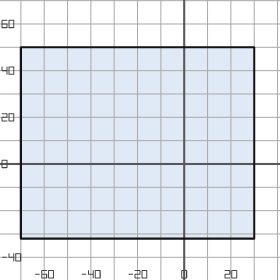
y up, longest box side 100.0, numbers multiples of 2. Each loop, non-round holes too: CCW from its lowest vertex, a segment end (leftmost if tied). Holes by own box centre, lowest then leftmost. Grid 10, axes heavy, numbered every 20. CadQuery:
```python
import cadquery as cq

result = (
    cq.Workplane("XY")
    .moveTo(-70.0, -32.0)
    .lineTo(30.0, -32.0)
    .lineTo(30.0, 50.0)
    .lineTo(-70.0, 50.0)
    .close()
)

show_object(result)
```